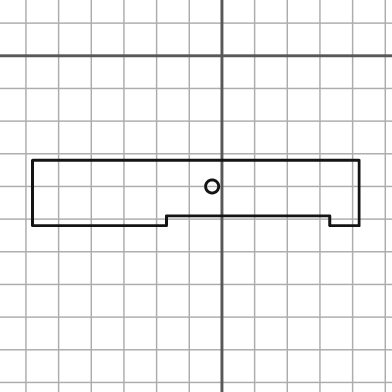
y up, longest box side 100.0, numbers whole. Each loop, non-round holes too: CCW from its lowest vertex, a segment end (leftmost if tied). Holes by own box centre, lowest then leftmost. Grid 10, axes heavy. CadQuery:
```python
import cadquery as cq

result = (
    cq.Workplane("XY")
    .moveTo(-58.0, -52.0)
    .lineTo(-17.0, -52.0)
    .lineTo(-17.0, -49.0)
    .lineTo(33.0, -49.0)
    .lineTo(33.0, -52.0)
    .lineTo(42.0, -52.0)
    .lineTo(42.0, -32.0)
    .lineTo(-58.0, -32.0)
    .close()
    .moveTo(-3.0, -40.0)
    .circle(2.0)
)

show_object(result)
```